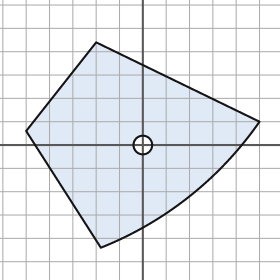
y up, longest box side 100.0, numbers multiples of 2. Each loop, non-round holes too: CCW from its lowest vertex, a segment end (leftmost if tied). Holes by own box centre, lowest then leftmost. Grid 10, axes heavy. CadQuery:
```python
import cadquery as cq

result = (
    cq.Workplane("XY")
    .moveTo(-18.0, -44.0)
    .threePointArc((20.0, -22.0), (50.0, 10.0))
    .lineTo(-20.0, 44.0)
    .lineTo(-50.0, 6.0)
    .close()
    .moveTo(0.0, 0.0)
    .circle(4.0)
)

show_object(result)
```